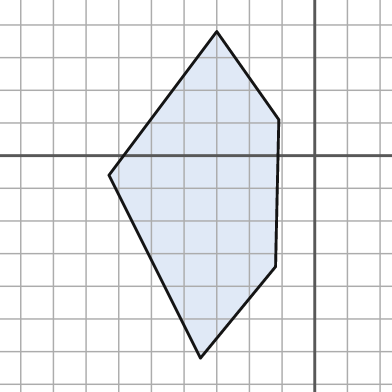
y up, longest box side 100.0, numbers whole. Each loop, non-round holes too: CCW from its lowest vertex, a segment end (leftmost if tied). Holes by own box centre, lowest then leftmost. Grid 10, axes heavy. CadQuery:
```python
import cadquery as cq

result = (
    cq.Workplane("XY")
    .moveTo(-35.0, -62.0)
    .lineTo(-12.0, -34.0)
    .lineTo(-11.0, 11.0)
    .lineTo(-30.0, 38.0)
    .lineTo(-63.0, -6.0)
    .close()
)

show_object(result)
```